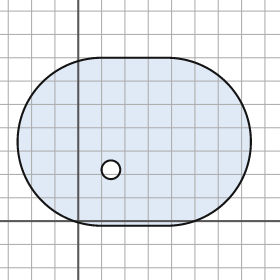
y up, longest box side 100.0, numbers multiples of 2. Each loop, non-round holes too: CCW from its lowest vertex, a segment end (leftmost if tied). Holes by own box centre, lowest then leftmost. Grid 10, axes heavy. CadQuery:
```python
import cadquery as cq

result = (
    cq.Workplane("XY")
    .moveTo(10.0, -2.0)
    .lineTo(38.0, -2.0)
    .threePointArc((74.0, 34.0), (38.0, 70.0))
    .lineTo(10.0, 70.0)
    .threePointArc((-26.0, 34.0), (10.0, -2.0))
    .close()
    .moveTo(14.0, 22.0)
    .circle(4.0)
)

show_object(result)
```